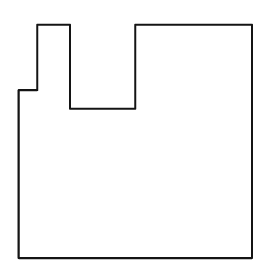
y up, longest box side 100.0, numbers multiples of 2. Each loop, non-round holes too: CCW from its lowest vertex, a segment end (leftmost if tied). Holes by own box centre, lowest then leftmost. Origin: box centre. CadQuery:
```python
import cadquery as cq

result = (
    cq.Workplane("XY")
    .moveTo(-50.0, -50.0)
    .lineTo(50.0, -50.0)
    .lineTo(50.0, 50.0)
    .lineTo(0.0, 50.0)
    .lineTo(0.0, 14.0)
    .lineTo(-28.0, 14.0)
    .lineTo(-28.0, 50.0)
    .lineTo(-42.0, 50.0)
    .lineTo(-42.0, 22.0)
    .lineTo(-50.0, 22.0)
    .close()
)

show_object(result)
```